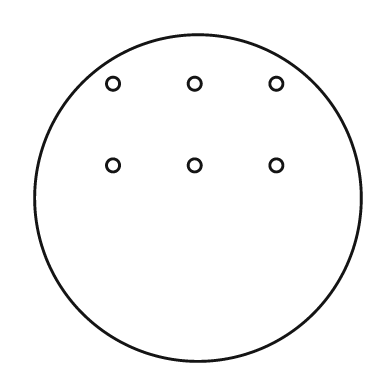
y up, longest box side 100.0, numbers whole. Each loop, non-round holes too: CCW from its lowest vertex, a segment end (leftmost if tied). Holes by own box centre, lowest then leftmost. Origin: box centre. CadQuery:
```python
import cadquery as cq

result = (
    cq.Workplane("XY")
    .moveTo(0.0, 0.0)
    .circle(50.0)
    .moveTo(-26.0, 10.0)
    .circle(2.0)
    .moveTo(-1.0, 10.0)
    .circle(2.0)
    .moveTo(24.0, 10.0)
    .circle(2.0)
    .moveTo(-26.0, 35.0)
    .circle(2.0)
    .moveTo(-1.0, 35.0)
    .circle(2.0)
    .moveTo(24.0, 35.0)
    .circle(2.0)
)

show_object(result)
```